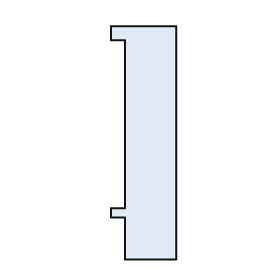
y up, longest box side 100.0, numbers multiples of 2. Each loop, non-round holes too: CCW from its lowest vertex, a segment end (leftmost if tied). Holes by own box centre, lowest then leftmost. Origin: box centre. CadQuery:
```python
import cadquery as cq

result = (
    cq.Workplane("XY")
    .moveTo(-8.0, -50.0)
    .lineTo(14.0, -50.0)
    .lineTo(14.0, 50.0)
    .lineTo(-14.0, 50.0)
    .lineTo(-14.0, 44.0)
    .lineTo(-8.0, 44.0)
    .lineTo(-8.0, -28.0)
    .lineTo(-14.0, -28.0)
    .lineTo(-14.0, -32.0)
    .lineTo(-8.0, -32.0)
    .close()
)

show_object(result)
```